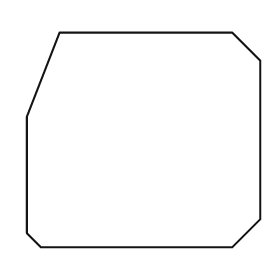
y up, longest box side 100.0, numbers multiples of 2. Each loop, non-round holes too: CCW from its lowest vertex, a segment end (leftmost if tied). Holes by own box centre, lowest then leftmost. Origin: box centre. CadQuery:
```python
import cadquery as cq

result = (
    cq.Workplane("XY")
    .moveTo(-44.0, -46.0)
    .lineTo(38.0, -46.0)
    .lineTo(50.0, -34.0)
    .lineTo(50.0, 34.0)
    .lineTo(38.0, 46.0)
    .lineTo(-36.0, 46.0)
    .lineTo(-50.0, 10.0)
    .lineTo(-50.0, -40.0)
    .close()
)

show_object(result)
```